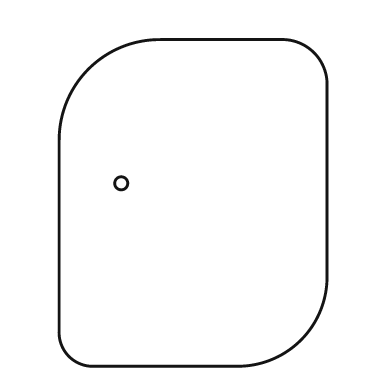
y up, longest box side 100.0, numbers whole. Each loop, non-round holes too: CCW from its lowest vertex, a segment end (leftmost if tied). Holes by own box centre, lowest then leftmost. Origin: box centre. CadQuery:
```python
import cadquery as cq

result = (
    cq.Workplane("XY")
    .moveTo(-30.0, -50.0)
    .lineTo(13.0, -50.0)
    .threePointArc((33.0, -42.0), (41.0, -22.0))
    .lineTo(41.0, 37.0)
    .threePointArc((37.0, 46.0), (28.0, 50.0))
    .lineTo(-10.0, 50.0)
    .threePointArc((-32.0, 41.0), (-41.0, 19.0))
    .lineTo(-41.0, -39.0)
    .threePointArc((-38.0, -47.0), (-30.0, -50.0))
    .close()
    .moveTo(-22.0, 6.0)
    .circle(2.0)
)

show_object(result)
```